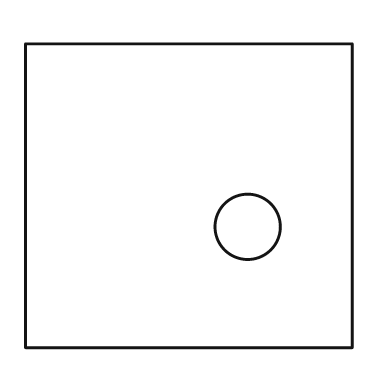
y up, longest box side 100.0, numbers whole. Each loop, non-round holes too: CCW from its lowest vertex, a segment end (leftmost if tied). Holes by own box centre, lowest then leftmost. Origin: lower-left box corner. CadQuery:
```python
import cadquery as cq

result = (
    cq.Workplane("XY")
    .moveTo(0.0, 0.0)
    .lineTo(100.0, 0.0)
    .lineTo(100.0, 93.0)
    .lineTo(0.0, 93.0)
    .close()
    .moveTo(68.0, 37.0)
    .circle(10.0)
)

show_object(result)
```